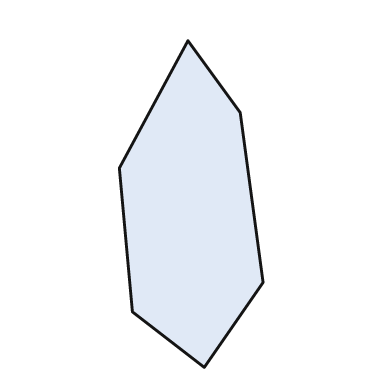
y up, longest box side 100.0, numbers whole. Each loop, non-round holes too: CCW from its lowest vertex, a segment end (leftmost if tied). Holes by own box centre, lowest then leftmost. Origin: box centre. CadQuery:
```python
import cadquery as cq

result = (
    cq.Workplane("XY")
    .moveTo(4.0, -50.0)
    .lineTo(22.0, -24.0)
    .lineTo(15.0, 28.0)
    .lineTo(-1.0, 50.0)
    .lineTo(-22.0, 11.0)
    .lineTo(-18.0, -33.0)
    .close()
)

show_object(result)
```